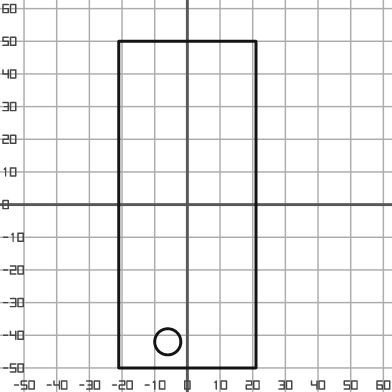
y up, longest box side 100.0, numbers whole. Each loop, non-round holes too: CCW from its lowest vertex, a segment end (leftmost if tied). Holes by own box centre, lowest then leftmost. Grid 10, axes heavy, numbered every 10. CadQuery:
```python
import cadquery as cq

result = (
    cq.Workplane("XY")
    .moveTo(-21.0, -50.0)
    .lineTo(21.0, -50.0)
    .lineTo(21.0, 50.0)
    .lineTo(-21.0, 50.0)
    .close()
    .moveTo(-6.0, -42.0)
    .circle(4.0)
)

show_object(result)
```